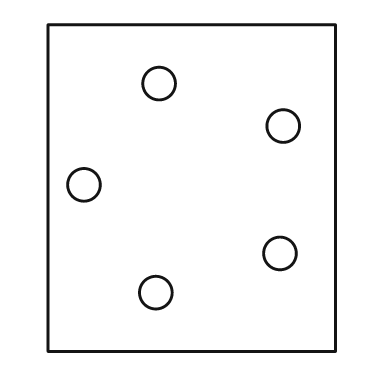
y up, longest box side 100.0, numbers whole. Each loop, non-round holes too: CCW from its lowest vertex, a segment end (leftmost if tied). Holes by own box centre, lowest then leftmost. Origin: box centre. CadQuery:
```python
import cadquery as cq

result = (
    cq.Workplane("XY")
    .moveTo(-44.0, -50.0)
    .lineTo(44.0, -50.0)
    .lineTo(44.0, 50.0)
    .lineTo(-44.0, 50.0)
    .close()
    .moveTo(-11.0, -32.0)
    .circle(5.0)
    .moveTo(27.0, -20.0)
    .circle(5.0)
    .moveTo(-33.0, 1.0)
    .circle(5.0)
    .moveTo(28.0, 19.0)
    .circle(5.0)
    .moveTo(-10.0, 32.0)
    .circle(5.0)
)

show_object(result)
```